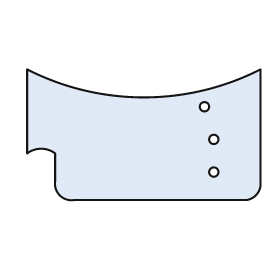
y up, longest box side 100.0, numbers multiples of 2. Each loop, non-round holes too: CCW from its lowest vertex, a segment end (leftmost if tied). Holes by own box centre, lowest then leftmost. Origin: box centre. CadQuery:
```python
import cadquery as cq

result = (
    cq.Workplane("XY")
    .moveTo(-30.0, -28.0)
    .lineTo(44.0, -28.0)
    .threePointArc((48.0, -26.0), (50.0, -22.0))
    .lineTo(50.0, 28.0)
    .threePointArc((0.0, 16.0), (-50.0, 28.0))
    .lineTo(-50.0, -8.0)
    .threePointArc((-44.0, -6.0), (-38.0, -8.0))
    .lineTo(-38.0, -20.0)
    .threePointArc((-36.0, -26.0), (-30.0, -28.0))
    .close()
    .moveTo(30.0, -16.0)
    .circle(2.0)
    .moveTo(30.0, -2.0)
    .circle(2.0)
    .moveTo(26.0, 12.0)
    .circle(2.0)
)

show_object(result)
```